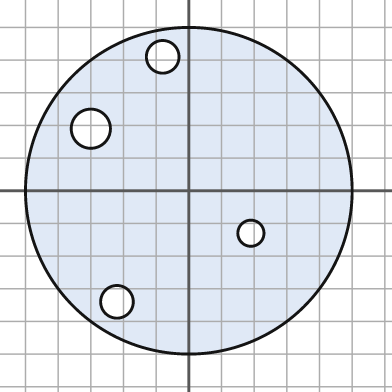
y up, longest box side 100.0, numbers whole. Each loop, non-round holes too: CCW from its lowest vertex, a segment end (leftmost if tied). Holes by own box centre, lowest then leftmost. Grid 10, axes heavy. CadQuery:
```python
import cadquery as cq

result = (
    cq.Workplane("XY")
    .moveTo(0.0, 0.0)
    .circle(50.0)
    .moveTo(-22.0, -34.0)
    .circle(5.0)
    .moveTo(19.0, -13.0)
    .circle(4.0)
    .moveTo(-30.0, 19.0)
    .circle(6.0)
    .moveTo(-8.0, 41.0)
    .circle(5.0)
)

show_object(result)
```